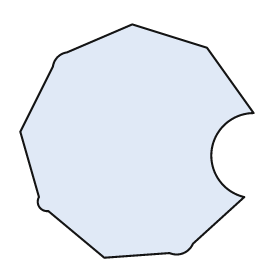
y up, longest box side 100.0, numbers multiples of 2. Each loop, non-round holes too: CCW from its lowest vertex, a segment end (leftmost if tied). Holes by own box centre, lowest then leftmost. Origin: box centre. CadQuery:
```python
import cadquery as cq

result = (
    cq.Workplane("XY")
    .moveTo(-14.0, -50.0)
    .lineTo(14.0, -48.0)
    .threePointArc((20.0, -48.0), (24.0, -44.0))
    .lineTo(46.0, -24.0)
    .threePointArc((32.0, -4.0), (50.0, 12.0))
    .lineTo(30.0, 40.0)
    .lineTo(-2.0, 50.0)
    .lineTo(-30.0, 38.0)
    .threePointArc((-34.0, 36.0), (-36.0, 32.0))
    .lineTo(-50.0, 4.0)
    .lineTo(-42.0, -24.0)
    .threePointArc((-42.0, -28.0), (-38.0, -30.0))
    .close()
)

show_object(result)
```